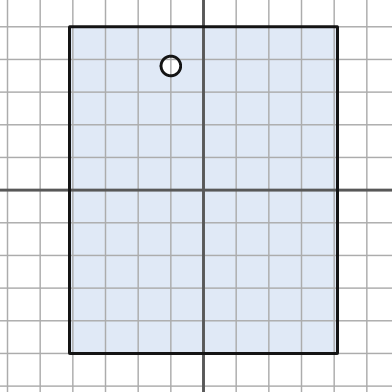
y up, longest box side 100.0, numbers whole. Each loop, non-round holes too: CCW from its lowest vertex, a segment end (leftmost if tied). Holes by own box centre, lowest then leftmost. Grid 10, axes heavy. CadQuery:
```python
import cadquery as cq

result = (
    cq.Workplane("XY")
    .moveTo(-41.0, -50.0)
    .lineTo(41.0, -50.0)
    .lineTo(41.0, 50.0)
    .lineTo(-41.0, 50.0)
    .close()
    .moveTo(-10.0, 38.0)
    .circle(3.0)
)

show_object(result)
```